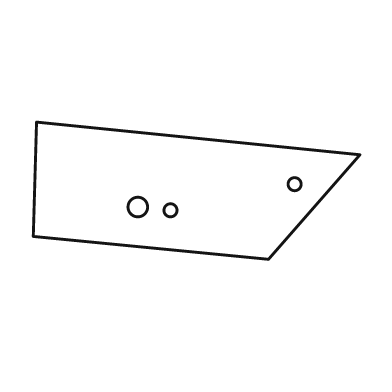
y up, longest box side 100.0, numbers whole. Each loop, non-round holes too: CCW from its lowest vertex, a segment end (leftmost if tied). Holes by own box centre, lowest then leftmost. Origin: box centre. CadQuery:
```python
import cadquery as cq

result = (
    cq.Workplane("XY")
    .moveTo(22.0, -21.0)
    .lineTo(50.0, 11.0)
    .lineTo(-49.0, 21.0)
    .lineTo(-50.0, -14.0)
    .close()
    .moveTo(-8.0, -6.0)
    .circle(2.0)
    .moveTo(-18.0, -5.0)
    .circle(3.0)
    .moveTo(30.0, 2.0)
    .circle(2.0)
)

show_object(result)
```